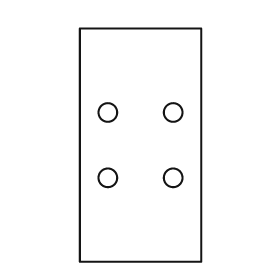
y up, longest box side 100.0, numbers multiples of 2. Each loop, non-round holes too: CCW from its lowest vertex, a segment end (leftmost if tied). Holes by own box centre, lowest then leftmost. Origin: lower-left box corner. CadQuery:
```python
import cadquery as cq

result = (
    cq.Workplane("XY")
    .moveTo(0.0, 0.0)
    .lineTo(52.0, 0.0)
    .lineTo(52.0, 100.0)
    .lineTo(0.0, 100.0)
    .close()
    .moveTo(12.0, 36.0)
    .circle(4.0)
    .moveTo(40.0, 36.0)
    .circle(4.0)
    .moveTo(12.0, 64.0)
    .circle(4.0)
    .moveTo(40.0, 64.0)
    .circle(4.0)
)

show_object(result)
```